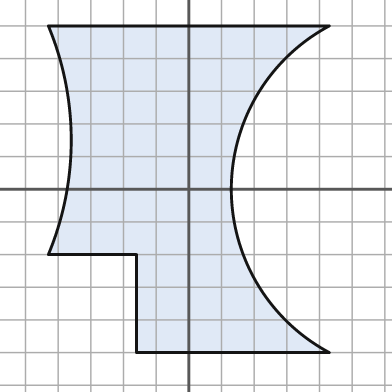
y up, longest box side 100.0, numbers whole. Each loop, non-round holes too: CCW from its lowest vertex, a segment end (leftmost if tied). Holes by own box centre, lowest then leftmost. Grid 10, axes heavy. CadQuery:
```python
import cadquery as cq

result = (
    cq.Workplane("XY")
    .moveTo(-16.0, -50.0)
    .lineTo(43.0, -50.0)
    .threePointArc((13.0, 0.0), (43.0, 50.0))
    .lineTo(-43.0, 50.0)
    .threePointArc((-36.0, 15.0), (-43.0, -20.0))
    .lineTo(-16.0, -20.0)
    .close()
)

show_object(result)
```